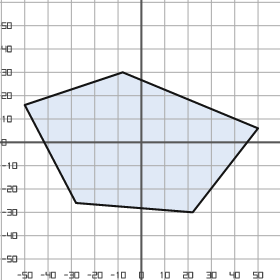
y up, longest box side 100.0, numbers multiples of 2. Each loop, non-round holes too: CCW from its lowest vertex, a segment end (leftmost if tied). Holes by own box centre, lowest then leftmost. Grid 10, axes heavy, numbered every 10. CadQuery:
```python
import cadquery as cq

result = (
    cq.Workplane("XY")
    .moveTo(22.0, -30.0)
    .lineTo(50.0, 6.0)
    .lineTo(-8.0, 30.0)
    .lineTo(-50.0, 16.0)
    .lineTo(-28.0, -26.0)
    .close()
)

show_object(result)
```